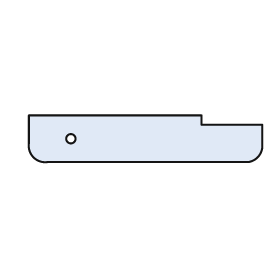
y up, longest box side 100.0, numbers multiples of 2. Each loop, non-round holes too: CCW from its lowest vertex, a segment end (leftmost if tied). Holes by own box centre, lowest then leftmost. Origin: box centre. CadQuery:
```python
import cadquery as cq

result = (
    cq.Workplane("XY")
    .moveTo(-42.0, -10.0)
    .lineTo(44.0, -10.0)
    .threePointArc((48.0, -8.0), (50.0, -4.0))
    .lineTo(50.0, 6.0)
    .lineTo(24.0, 6.0)
    .lineTo(24.0, 10.0)
    .lineTo(-50.0, 10.0)
    .lineTo(-50.0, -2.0)
    .threePointArc((-48.0, -8.0), (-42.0, -10.0))
    .close()
    .moveTo(-32.0, 0.0)
    .circle(2.0)
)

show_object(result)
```